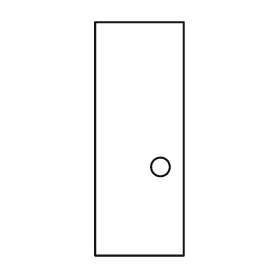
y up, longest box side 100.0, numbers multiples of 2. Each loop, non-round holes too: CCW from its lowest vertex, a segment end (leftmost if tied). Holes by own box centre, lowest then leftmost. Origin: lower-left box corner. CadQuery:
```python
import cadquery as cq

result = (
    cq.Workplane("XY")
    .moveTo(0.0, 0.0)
    .lineTo(38.0, 0.0)
    .lineTo(38.0, 100.0)
    .lineTo(0.0, 100.0)
    .close()
    .moveTo(28.0, 38.0)
    .circle(4.0)
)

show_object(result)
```